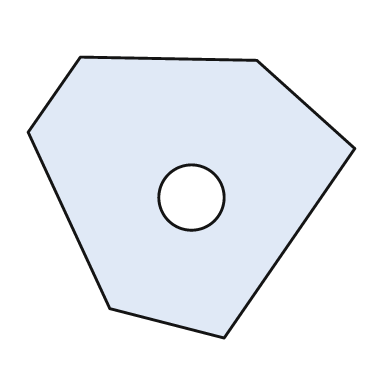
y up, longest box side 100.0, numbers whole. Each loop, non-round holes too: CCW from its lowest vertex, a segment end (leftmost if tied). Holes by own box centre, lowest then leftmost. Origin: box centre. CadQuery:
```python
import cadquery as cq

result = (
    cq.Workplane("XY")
    .moveTo(10.0, -43.0)
    .lineTo(50.0, 15.0)
    .lineTo(20.0, 42.0)
    .lineTo(-34.0, 43.0)
    .lineTo(-50.0, 20.0)
    .lineTo(-25.0, -34.0)
    .close()
    .moveTo(0.0, 0.0)
    .circle(10.0)
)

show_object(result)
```